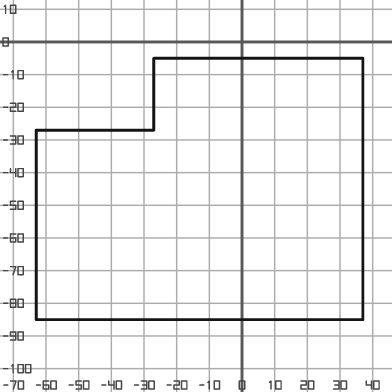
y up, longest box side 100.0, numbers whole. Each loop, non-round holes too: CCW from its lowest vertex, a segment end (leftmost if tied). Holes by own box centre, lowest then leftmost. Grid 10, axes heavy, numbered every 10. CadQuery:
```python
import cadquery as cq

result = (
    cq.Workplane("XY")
    .moveTo(-63.0, -85.0)
    .lineTo(37.0, -85.0)
    .lineTo(37.0, -5.0)
    .lineTo(-27.0, -5.0)
    .lineTo(-27.0, -27.0)
    .lineTo(-63.0, -27.0)
    .close()
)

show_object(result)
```